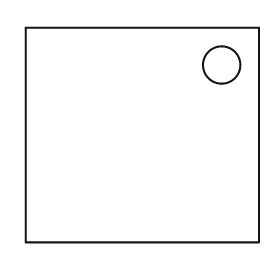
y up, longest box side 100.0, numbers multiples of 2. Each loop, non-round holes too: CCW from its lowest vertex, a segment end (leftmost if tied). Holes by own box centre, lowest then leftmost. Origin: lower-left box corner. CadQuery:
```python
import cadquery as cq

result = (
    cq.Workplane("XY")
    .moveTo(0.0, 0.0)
    .lineTo(100.0, 0.0)
    .lineTo(100.0, 92.0)
    .lineTo(0.0, 92.0)
    .close()
    .moveTo(84.0, 76.0)
    .circle(8.0)
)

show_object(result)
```